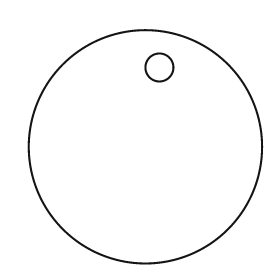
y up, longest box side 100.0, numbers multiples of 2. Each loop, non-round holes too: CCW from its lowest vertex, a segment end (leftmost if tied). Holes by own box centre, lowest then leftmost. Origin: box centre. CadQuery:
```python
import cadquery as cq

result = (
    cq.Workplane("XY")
    .moveTo(0.0, 0.0)
    .circle(50.0)
    .moveTo(6.0, 34.0)
    .circle(6.0)
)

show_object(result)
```